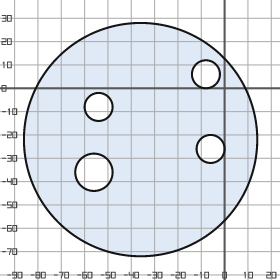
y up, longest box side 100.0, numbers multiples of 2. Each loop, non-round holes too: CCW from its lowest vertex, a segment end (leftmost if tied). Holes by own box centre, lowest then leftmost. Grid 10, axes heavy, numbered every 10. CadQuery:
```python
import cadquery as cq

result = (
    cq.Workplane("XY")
    .moveTo(-36.0, -22.0)
    .circle(50.0)
    .moveTo(-56.0, -36.0)
    .circle(8.0)
    .moveTo(-6.0, -26.0)
    .circle(6.0)
    .moveTo(-54.0, -8.0)
    .circle(6.0)
    .moveTo(-8.0, 6.0)
    .circle(6.0)
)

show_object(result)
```